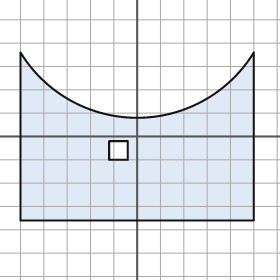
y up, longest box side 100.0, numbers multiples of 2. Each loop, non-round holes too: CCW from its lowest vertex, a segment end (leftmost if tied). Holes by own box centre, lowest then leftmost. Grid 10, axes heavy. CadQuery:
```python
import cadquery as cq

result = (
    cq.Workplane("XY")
    .moveTo(-50.0, -36.0)
    .lineTo(50.0, -36.0)
    .lineTo(50.0, 36.0)
    .threePointArc((0.0, 8.0), (-50.0, 36.0))
    .close()
    .moveTo(-12.0, -10.0)
    .lineTo(-4.0, -10.0)
    .lineTo(-4.0, -2.0)
    .lineTo(-12.0, -2.0)
    .close()
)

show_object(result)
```